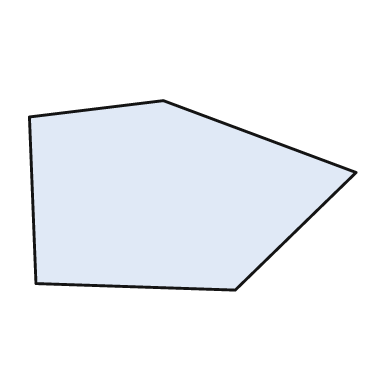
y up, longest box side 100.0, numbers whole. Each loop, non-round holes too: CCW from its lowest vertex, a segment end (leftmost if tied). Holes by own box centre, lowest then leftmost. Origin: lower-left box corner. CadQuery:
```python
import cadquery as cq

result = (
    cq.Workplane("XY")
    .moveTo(63.0, 0.0)
    .lineTo(100.0, 36.0)
    .lineTo(41.0, 58.0)
    .lineTo(0.0, 53.0)
    .lineTo(2.0, 2.0)
    .close()
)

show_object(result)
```